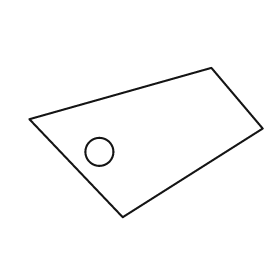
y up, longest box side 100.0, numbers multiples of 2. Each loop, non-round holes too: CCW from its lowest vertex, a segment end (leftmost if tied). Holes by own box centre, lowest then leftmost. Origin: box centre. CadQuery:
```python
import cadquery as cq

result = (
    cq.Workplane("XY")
    .moveTo(-10.0, -32.0)
    .lineTo(50.0, 6.0)
    .lineTo(28.0, 32.0)
    .lineTo(-50.0, 10.0)
    .close()
    .moveTo(-20.0, -4.0)
    .circle(6.0)
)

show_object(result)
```